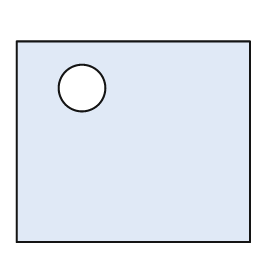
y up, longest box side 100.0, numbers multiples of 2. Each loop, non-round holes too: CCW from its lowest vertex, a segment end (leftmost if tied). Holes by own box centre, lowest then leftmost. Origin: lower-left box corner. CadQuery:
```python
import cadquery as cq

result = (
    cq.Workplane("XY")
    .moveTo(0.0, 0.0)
    .lineTo(100.0, 0.0)
    .lineTo(100.0, 86.0)
    .lineTo(0.0, 86.0)
    .close()
    .moveTo(28.0, 66.0)
    .circle(10.0)
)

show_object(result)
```